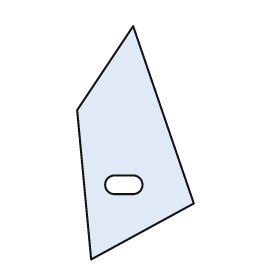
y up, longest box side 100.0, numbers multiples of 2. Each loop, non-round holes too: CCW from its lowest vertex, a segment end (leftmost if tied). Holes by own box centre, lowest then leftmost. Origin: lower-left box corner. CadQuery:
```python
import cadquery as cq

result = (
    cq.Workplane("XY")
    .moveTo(6.0, 0.0)
    .lineTo(50.0, 24.0)
    .lineTo(24.0, 100.0)
    .lineTo(0.0, 64.0)
    .close()
    .moveTo(16.0, 28.0)
    .lineTo(24.0, 28.0)
    .threePointArc((28.0, 32.0), (24.0, 36.0))
    .lineTo(16.0, 36.0)
    .threePointArc((12.0, 32.0), (16.0, 28.0))
    .close()
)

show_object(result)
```